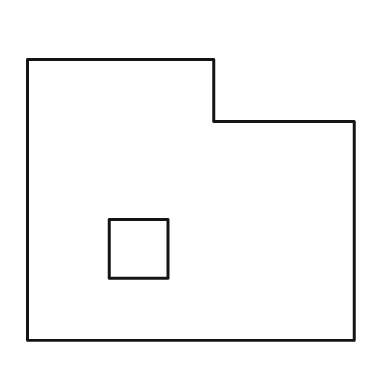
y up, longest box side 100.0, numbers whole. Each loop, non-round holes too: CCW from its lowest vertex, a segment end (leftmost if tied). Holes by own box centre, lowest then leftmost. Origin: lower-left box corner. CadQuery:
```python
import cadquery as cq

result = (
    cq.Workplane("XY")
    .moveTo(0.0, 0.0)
    .lineTo(100.0, 0.0)
    .lineTo(100.0, 67.0)
    .lineTo(57.0, 67.0)
    .lineTo(57.0, 86.0)
    .lineTo(0.0, 86.0)
    .close()
    .moveTo(25.0, 19.0)
    .lineTo(43.0, 19.0)
    .lineTo(43.0, 37.0)
    .lineTo(25.0, 37.0)
    .close()
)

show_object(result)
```